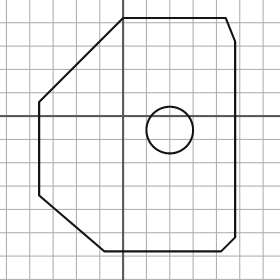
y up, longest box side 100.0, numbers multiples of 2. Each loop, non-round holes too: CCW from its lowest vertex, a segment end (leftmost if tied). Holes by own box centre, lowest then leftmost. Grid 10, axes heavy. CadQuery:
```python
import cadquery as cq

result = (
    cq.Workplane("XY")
    .moveTo(-8.0, -58.0)
    .lineTo(42.0, -58.0)
    .lineTo(48.0, -52.0)
    .lineTo(48.0, 32.0)
    .lineTo(44.0, 42.0)
    .lineTo(0.0, 42.0)
    .lineTo(-36.0, 6.0)
    .lineTo(-36.0, -34.0)
    .close()
    .moveTo(20.0, -6.0)
    .circle(10.0)
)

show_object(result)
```